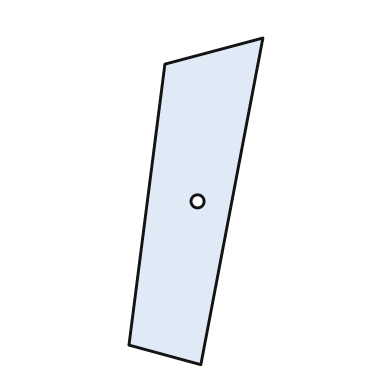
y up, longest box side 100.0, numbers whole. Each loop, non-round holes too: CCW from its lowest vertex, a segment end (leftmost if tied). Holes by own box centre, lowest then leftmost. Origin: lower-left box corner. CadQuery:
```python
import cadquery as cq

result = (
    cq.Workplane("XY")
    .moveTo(22.0, 0.0)
    .lineTo(41.0, 100.0)
    .lineTo(11.0, 92.0)
    .lineTo(0.0, 6.0)
    .close()
    .moveTo(21.0, 50.0)
    .circle(2.0)
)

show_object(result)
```